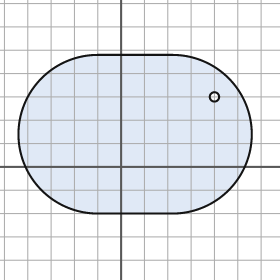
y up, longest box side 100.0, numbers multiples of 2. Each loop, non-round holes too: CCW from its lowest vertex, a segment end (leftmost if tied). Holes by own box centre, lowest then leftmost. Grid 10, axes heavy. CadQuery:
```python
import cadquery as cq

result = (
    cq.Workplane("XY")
    .moveTo(-10.0, -20.0)
    .lineTo(22.0, -20.0)
    .threePointArc((56.0, 14.0), (22.0, 48.0))
    .lineTo(-10.0, 48.0)
    .threePointArc((-44.0, 14.0), (-10.0, -20.0))
    .close()
    .moveTo(40.0, 30.0)
    .circle(2.0)
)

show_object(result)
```